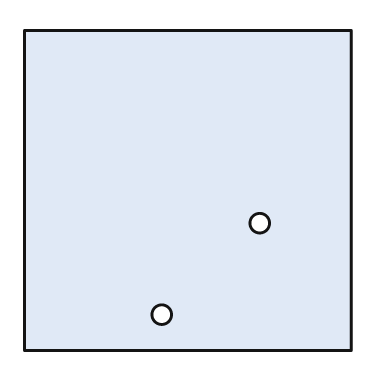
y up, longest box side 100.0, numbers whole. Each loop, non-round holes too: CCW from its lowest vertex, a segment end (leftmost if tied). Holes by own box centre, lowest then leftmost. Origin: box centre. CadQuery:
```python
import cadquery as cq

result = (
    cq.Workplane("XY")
    .moveTo(-50.0, -49.0)
    .lineTo(50.0, -49.0)
    .lineTo(50.0, 49.0)
    .lineTo(-50.0, 49.0)
    .close()
    .moveTo(-8.0, -38.0)
    .circle(3.0)
    .moveTo(22.0, -10.0)
    .circle(3.0)
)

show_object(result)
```